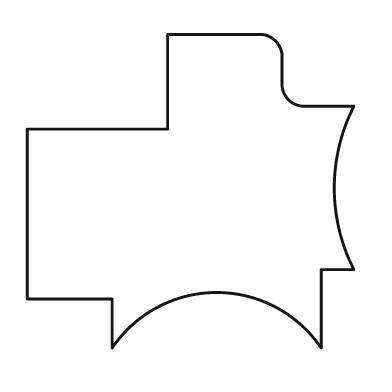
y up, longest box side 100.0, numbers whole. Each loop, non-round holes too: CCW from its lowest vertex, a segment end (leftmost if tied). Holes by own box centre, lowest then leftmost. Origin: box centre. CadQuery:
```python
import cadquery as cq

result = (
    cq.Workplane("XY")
    .moveTo(-24.0, -48.0)
    .threePointArc((8.0, -31.0), (40.0, -48.0))
    .lineTo(40.0, -24.0)
    .lineTo(50.0, -24.0)
    .threePointArc((44.0, 1.0), (50.0, 26.0))
    .lineTo(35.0, 26.0)
    .threePointArc((30.0, 28.0), (28.0, 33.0))
    .lineTo(28.0, 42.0)
    .threePointArc((26.0, 46.0), (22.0, 48.0))
    .lineTo(-7.0, 48.0)
    .lineTo(-7.0, 19.0)
    .lineTo(-50.0, 19.0)
    .lineTo(-50.0, -33.0)
    .lineTo(-24.0, -33.0)
    .close()
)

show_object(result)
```